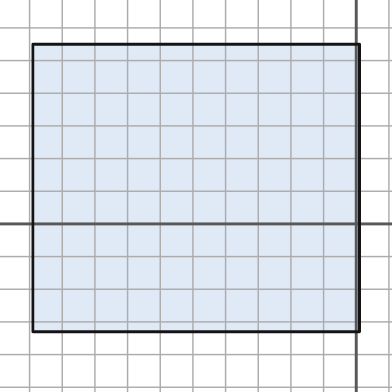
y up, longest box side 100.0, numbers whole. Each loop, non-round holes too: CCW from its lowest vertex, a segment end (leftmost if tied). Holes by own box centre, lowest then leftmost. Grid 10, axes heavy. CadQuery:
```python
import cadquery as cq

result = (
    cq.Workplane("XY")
    .moveTo(-99.0, -33.0)
    .lineTo(1.0, -33.0)
    .lineTo(1.0, 55.0)
    .lineTo(-99.0, 55.0)
    .close()
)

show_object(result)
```